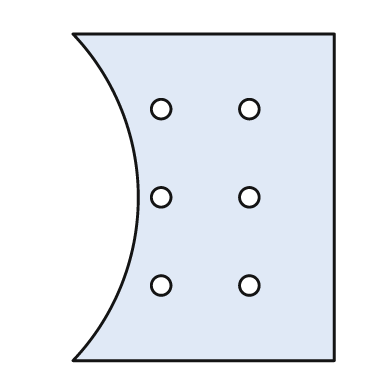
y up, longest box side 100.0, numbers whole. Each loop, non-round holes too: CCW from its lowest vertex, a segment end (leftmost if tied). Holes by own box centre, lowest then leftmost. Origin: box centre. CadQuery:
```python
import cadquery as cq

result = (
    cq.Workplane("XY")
    .moveTo(-40.0, -50.0)
    .lineTo(40.0, -50.0)
    .lineTo(40.0, 50.0)
    .lineTo(-40.0, 50.0)
    .threePointArc((-20.0, 0.0), (-40.0, -50.0))
    .close()
    .moveTo(-13.0, -27.0)
    .circle(3.0)
    .moveTo(14.0, -27.0)
    .circle(3.0)
    .moveTo(-13.0, 0.0)
    .circle(3.0)
    .moveTo(14.0, 0.0)
    .circle(3.0)
    .moveTo(-13.0, 27.0)
    .circle(3.0)
    .moveTo(14.0, 27.0)
    .circle(3.0)
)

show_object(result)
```